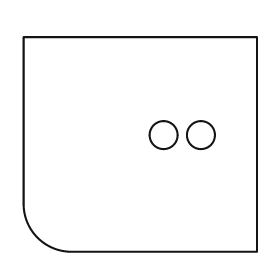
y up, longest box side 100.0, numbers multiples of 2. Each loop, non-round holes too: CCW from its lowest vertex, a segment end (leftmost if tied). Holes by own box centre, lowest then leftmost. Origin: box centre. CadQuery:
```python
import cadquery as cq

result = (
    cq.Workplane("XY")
    .moveTo(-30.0, -46.0)
    .lineTo(50.0, -46.0)
    .lineTo(50.0, 46.0)
    .lineTo(-50.0, 46.0)
    .lineTo(-50.0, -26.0)
    .threePointArc((-44.0, -40.0), (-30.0, -46.0))
    .close()
    .moveTo(10.0, 4.0)
    .circle(6.0)
    .moveTo(26.0, 4.0)
    .circle(6.0)
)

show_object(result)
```